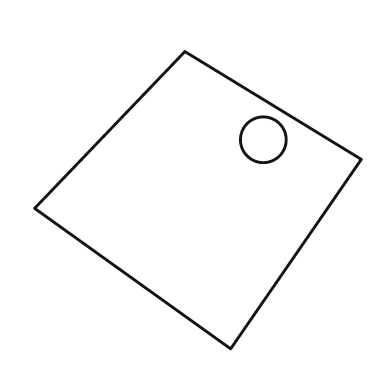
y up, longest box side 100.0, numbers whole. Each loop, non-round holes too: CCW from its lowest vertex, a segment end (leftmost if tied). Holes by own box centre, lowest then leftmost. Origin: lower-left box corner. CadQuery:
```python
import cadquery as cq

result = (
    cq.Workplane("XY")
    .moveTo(60.0, 0.0)
    .lineTo(100.0, 58.0)
    .lineTo(46.0, 91.0)
    .lineTo(0.0, 43.0)
    .close()
    .moveTo(70.0, 64.0)
    .circle(7.0)
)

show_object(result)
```